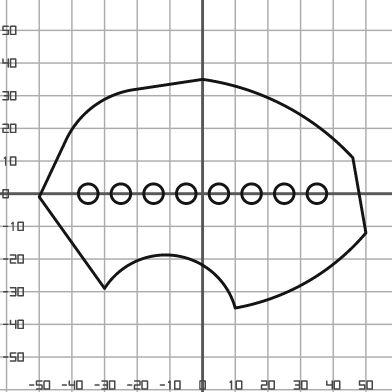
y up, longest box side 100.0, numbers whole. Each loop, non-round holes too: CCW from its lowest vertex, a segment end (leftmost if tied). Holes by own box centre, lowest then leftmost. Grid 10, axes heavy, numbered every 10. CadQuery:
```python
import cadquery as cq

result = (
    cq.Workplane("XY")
    .moveTo(10.0, -35.0)
    .threePointArc((32.0, -27.0), (50.0, -12.0))
    .lineTo(46.0, 11.0)
    .threePointArc((25.0, 27.0), (0.0, 35.0))
    .lineTo(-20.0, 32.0)
    .threePointArc((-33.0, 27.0), (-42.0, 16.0))
    .lineTo(-50.0, -1.0)
    .lineTo(-30.0, -29.0)
    .threePointArc((-8.0, -19.0), (10.0, -35.0))
    .close()
    .moveTo(-35.0, 0.0)
    .circle(3.0)
    .moveTo(-25.0, 0.0)
    .circle(3.0)
    .moveTo(-15.0, 0.0)
    .circle(3.0)
    .moveTo(-5.0, 0.0)
    .circle(3.0)
    .moveTo(5.0, 0.0)
    .circle(3.0)
    .moveTo(15.0, 0.0)
    .circle(3.0)
    .moveTo(25.0, 0.0)
    .circle(3.0)
    .moveTo(35.0, 0.0)
    .circle(3.0)
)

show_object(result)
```